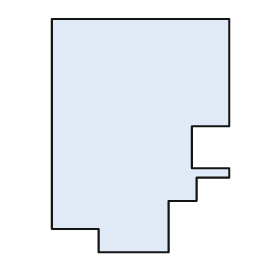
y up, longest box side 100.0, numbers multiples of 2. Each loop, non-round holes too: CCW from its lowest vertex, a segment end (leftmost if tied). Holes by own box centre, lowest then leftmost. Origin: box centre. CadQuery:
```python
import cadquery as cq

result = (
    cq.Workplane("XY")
    .moveTo(-18.0, -50.0)
    .lineTo(12.0, -50.0)
    .lineTo(12.0, -28.0)
    .lineTo(24.0, -28.0)
    .lineTo(24.0, -18.0)
    .lineTo(38.0, -18.0)
    .lineTo(38.0, -14.0)
    .lineTo(22.0, -14.0)
    .lineTo(22.0, 4.0)
    .lineTo(38.0, 4.0)
    .lineTo(38.0, 50.0)
    .lineTo(-38.0, 50.0)
    .lineTo(-38.0, -40.0)
    .lineTo(-18.0, -40.0)
    .close()
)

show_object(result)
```